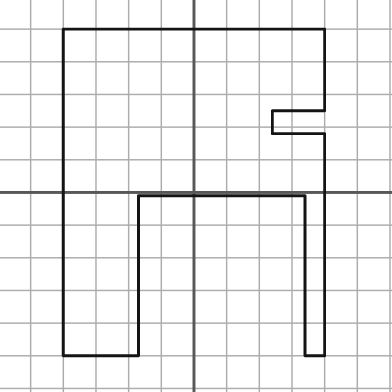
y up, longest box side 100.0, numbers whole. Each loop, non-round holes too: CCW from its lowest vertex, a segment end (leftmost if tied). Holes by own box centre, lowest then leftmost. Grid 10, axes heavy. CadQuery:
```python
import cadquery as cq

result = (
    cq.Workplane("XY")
    .moveTo(-40.0, -50.0)
    .lineTo(-17.0, -50.0)
    .lineTo(-17.0, -1.0)
    .lineTo(34.0, -1.0)
    .lineTo(34.0, -50.0)
    .lineTo(40.0, -50.0)
    .lineTo(40.0, 18.0)
    .lineTo(24.0, 18.0)
    .lineTo(24.0, 25.0)
    .lineTo(40.0, 25.0)
    .lineTo(40.0, 50.0)
    .lineTo(-40.0, 50.0)
    .close()
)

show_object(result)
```